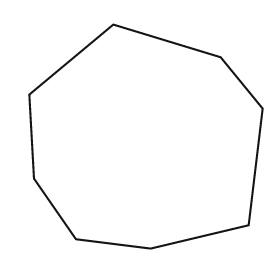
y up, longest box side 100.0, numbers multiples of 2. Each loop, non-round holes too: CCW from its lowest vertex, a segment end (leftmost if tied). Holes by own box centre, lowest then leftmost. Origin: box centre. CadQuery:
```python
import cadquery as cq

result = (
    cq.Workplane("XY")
    .moveTo(2.0, -48.0)
    .lineTo(44.0, -38.0)
    .lineTo(50.0, 12.0)
    .lineTo(32.0, 34.0)
    .lineTo(-14.0, 48.0)
    .lineTo(-50.0, 18.0)
    .lineTo(-48.0, -18.0)
    .lineTo(-30.0, -44.0)
    .close()
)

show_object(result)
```